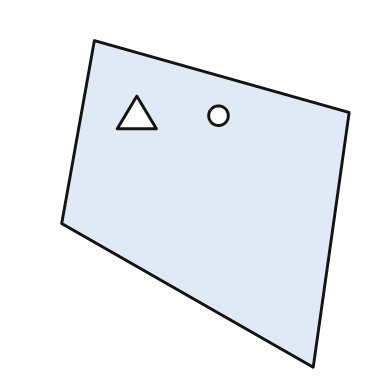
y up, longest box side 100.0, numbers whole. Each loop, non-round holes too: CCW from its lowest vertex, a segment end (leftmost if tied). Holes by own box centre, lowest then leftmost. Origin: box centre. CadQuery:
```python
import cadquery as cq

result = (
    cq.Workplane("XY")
    .moveTo(33.0, -50.0)
    .lineTo(44.0, 28.0)
    .lineTo(-34.0, 50.0)
    .lineTo(-44.0, -6.0)
    .close()
    .moveTo(4.0, 27.0)
    .circle(3.0)
    .moveTo(-27.0, 23.0)
    .lineTo(-15.0, 23.0)
    .lineTo(-21.0, 33.0)
    .close()
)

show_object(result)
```